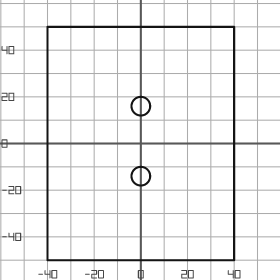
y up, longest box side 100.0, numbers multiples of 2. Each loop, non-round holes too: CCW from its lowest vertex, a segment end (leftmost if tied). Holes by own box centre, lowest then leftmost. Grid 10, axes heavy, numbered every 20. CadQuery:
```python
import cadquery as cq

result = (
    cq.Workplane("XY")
    .moveTo(-40.0, -50.0)
    .lineTo(40.0, -50.0)
    .lineTo(40.0, 50.0)
    .lineTo(-40.0, 50.0)
    .close()
    .moveTo(0.0, -14.0)
    .circle(4.0)
    .moveTo(0.0, 16.0)
    .circle(4.0)
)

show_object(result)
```